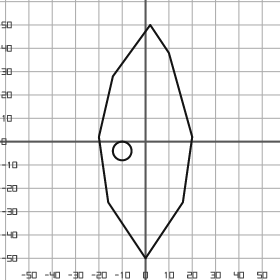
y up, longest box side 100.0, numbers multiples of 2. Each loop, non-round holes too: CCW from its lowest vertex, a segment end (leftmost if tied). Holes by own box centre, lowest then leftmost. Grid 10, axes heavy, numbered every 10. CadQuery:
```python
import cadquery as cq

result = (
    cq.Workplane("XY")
    .moveTo(0.0, -50.0)
    .lineTo(16.0, -26.0)
    .lineTo(20.0, 2.0)
    .lineTo(10.0, 38.0)
    .lineTo(2.0, 50.0)
    .lineTo(-14.0, 28.0)
    .lineTo(-20.0, 2.0)
    .lineTo(-16.0, -26.0)
    .close()
    .moveTo(-10.0, -4.0)
    .circle(4.0)
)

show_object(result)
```